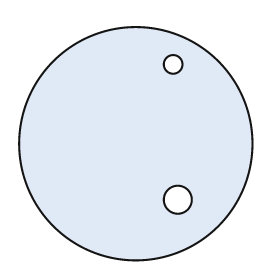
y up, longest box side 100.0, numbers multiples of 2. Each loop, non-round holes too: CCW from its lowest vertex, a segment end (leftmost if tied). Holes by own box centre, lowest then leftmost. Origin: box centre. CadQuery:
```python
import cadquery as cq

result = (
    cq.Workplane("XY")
    .moveTo(0.0, 0.0)
    .circle(50.0)
    .moveTo(18.0, -24.0)
    .circle(6.0)
    .moveTo(16.0, 34.0)
    .circle(4.0)
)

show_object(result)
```